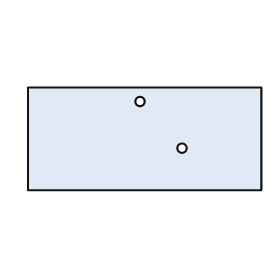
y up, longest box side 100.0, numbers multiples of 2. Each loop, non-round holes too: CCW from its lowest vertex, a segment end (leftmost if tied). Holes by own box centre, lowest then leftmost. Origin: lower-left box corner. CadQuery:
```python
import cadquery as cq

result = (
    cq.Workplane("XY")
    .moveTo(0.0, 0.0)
    .lineTo(100.0, 0.0)
    .lineTo(100.0, 44.0)
    .lineTo(0.0, 44.0)
    .close()
    .moveTo(66.0, 18.0)
    .circle(2.0)
    .moveTo(48.0, 38.0)
    .circle(2.0)
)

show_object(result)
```